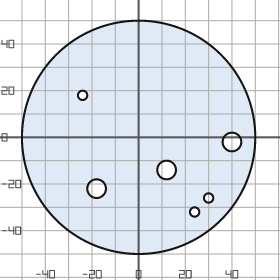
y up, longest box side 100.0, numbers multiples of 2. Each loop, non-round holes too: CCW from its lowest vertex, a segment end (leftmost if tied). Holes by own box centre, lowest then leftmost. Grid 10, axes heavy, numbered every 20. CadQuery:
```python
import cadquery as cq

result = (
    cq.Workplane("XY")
    .moveTo(0.0, 0.0)
    .circle(50.0)
    .moveTo(24.0, -32.0)
    .circle(2.0)
    .moveTo(30.0, -26.0)
    .circle(2.0)
    .moveTo(-18.0, -22.0)
    .circle(4.0)
    .moveTo(12.0, -14.0)
    .circle(4.0)
    .moveTo(40.0, -2.0)
    .circle(4.0)
    .moveTo(-24.0, 18.0)
    .circle(2.0)
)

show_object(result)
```